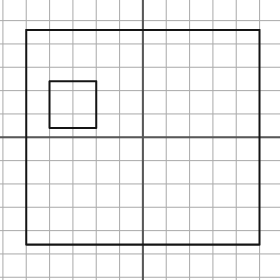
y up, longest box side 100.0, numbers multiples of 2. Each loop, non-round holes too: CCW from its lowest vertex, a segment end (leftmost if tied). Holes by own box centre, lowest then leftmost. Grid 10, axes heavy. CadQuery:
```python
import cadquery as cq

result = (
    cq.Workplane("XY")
    .moveTo(-50.0, -46.0)
    .lineTo(50.0, -46.0)
    .lineTo(50.0, 46.0)
    .lineTo(-50.0, 46.0)
    .close()
    .moveTo(-40.0, 4.0)
    .lineTo(-20.0, 4.0)
    .lineTo(-20.0, 24.0)
    .lineTo(-40.0, 24.0)
    .close()
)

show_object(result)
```